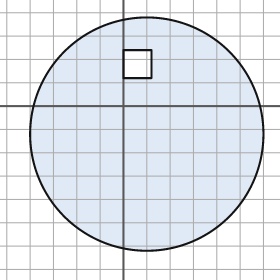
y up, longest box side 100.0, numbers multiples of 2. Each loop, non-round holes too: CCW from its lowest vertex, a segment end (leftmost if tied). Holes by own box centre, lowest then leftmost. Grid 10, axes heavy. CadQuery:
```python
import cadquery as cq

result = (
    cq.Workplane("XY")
    .moveTo(10.0, -12.0)
    .circle(50.0)
    .moveTo(0.0, 12.0)
    .lineTo(12.0, 12.0)
    .lineTo(12.0, 24.0)
    .lineTo(0.0, 24.0)
    .close()
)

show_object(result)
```